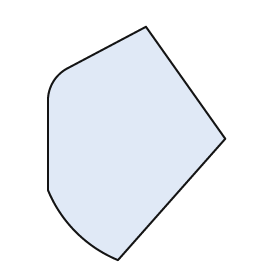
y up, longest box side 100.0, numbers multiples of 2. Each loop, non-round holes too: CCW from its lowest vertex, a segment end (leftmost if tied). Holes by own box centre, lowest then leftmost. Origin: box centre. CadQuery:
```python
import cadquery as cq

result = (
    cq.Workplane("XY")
    .moveTo(-8.0, -50.0)
    .lineTo(38.0, 2.0)
    .lineTo(4.0, 50.0)
    .lineTo(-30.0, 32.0)
    .threePointArc((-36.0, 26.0), (-38.0, 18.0))
    .lineTo(-38.0, -20.0)
    .threePointArc((-26.0, -38.0), (-8.0, -50.0))
    .close()
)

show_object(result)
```